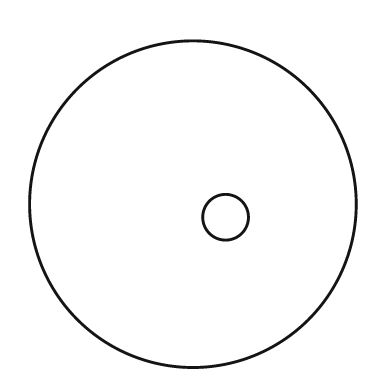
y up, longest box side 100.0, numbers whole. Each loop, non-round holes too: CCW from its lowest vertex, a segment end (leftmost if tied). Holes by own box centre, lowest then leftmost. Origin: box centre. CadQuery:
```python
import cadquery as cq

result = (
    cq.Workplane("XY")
    .moveTo(0.0, 0.0)
    .circle(50.0)
    .moveTo(10.0, -4.0)
    .circle(7.0)
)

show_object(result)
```